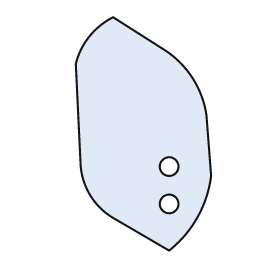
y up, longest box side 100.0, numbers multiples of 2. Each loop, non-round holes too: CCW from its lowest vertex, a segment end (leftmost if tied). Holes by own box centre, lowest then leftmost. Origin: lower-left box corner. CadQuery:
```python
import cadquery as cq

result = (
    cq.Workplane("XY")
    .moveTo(40.0, 0.0)
    .threePointArc((52.0, 14.0), (58.0, 32.0))
    .lineTo(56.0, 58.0)
    .threePointArc((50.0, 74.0), (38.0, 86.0))
    .lineTo(16.0, 100.0)
    .threePointArc((6.0, 92.0), (0.0, 80.0))
    .lineTo(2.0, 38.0)
    .threePointArc((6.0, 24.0), (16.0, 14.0))
    .close()
    .moveTo(40.0, 20.0)
    .circle(4.0)
    .moveTo(40.0, 36.0)
    .circle(4.0)
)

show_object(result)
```